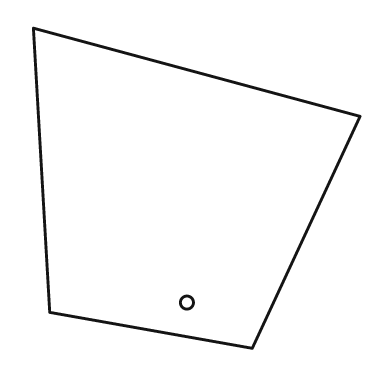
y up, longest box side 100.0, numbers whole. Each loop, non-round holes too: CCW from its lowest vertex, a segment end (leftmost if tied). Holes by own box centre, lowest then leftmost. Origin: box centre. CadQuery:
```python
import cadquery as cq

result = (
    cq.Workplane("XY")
    .moveTo(17.0, -49.0)
    .lineTo(50.0, 22.0)
    .lineTo(-50.0, 49.0)
    .lineTo(-45.0, -38.0)
    .close()
    .moveTo(-3.0, -35.0)
    .circle(2.0)
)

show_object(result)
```